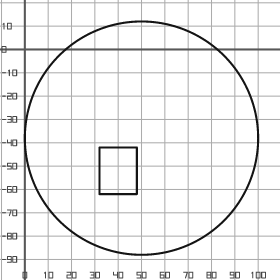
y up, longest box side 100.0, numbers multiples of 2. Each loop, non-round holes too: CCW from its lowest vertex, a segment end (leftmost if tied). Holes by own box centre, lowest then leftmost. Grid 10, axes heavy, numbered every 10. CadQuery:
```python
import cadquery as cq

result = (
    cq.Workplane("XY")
    .moveTo(50.0, -38.0)
    .circle(50.0)
    .moveTo(32.0, -62.0)
    .lineTo(48.0, -62.0)
    .lineTo(48.0, -42.0)
    .lineTo(32.0, -42.0)
    .close()
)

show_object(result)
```